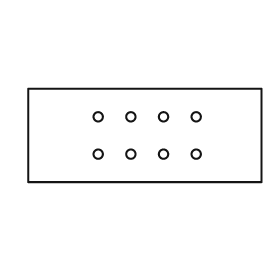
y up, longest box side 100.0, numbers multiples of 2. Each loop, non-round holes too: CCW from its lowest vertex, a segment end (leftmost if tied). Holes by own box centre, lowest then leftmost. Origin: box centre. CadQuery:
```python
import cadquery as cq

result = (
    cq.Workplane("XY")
    .moveTo(-50.0, -20.0)
    .lineTo(50.0, -20.0)
    .lineTo(50.0, 20.0)
    .lineTo(-50.0, 20.0)
    .close()
    .moveTo(-20.0, -8.0)
    .circle(2.0)
    .moveTo(-6.0, -8.0)
    .circle(2.0)
    .moveTo(8.0, -8.0)
    .circle(2.0)
    .moveTo(22.0, -8.0)
    .circle(2.0)
    .moveTo(-20.0, 8.0)
    .circle(2.0)
    .moveTo(-6.0, 8.0)
    .circle(2.0)
    .moveTo(8.0, 8.0)
    .circle(2.0)
    .moveTo(22.0, 8.0)
    .circle(2.0)
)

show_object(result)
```